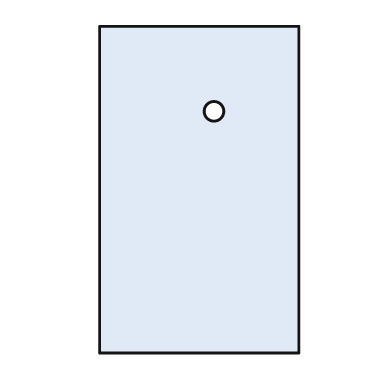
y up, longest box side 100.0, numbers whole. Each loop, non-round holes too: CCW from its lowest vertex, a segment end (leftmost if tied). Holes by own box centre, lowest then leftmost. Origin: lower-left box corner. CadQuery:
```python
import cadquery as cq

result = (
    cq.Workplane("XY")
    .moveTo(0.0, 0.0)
    .lineTo(61.0, 0.0)
    .lineTo(61.0, 100.0)
    .lineTo(0.0, 100.0)
    .close()
    .moveTo(35.0, 74.0)
    .circle(3.0)
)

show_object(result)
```